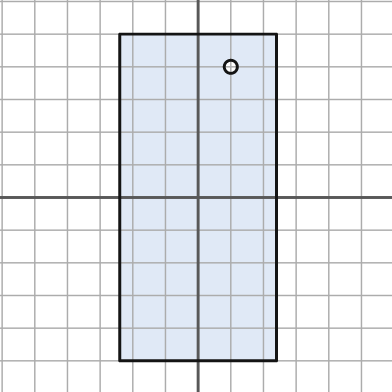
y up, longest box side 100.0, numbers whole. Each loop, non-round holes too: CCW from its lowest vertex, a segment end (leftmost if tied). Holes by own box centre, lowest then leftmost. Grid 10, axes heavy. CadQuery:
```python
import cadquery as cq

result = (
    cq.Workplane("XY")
    .moveTo(-24.0, -50.0)
    .lineTo(24.0, -50.0)
    .lineTo(24.0, 50.0)
    .lineTo(-24.0, 50.0)
    .close()
    .moveTo(10.0, 40.0)
    .circle(2.0)
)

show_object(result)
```